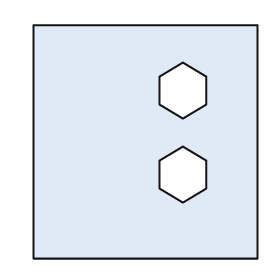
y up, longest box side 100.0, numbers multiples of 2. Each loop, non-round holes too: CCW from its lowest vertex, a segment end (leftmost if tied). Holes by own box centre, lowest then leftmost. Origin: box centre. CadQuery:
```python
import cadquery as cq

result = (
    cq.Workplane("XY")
    .moveTo(-48.0, -50.0)
    .lineTo(48.0, -50.0)
    .lineTo(48.0, 50.0)
    .lineTo(-48.0, 50.0)
    .close()
    .moveTo(16.0, -26.0)
    .lineTo(26.0, -20.0)
    .lineTo(26.0, -8.0)
    .lineTo(16.0, -2.0)
    .lineTo(6.0, -8.0)
    .lineTo(6.0, -20.0)
    .close()
    .moveTo(16.0, 10.0)
    .lineTo(26.0, 16.0)
    .lineTo(26.0, 28.0)
    .lineTo(16.0, 34.0)
    .lineTo(6.0, 28.0)
    .lineTo(6.0, 16.0)
    .close()
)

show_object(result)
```